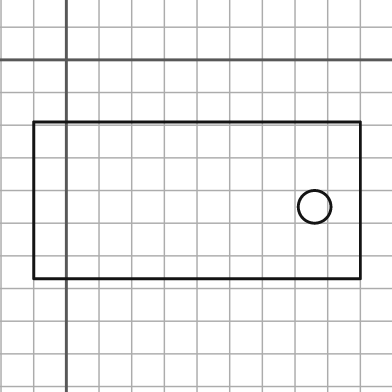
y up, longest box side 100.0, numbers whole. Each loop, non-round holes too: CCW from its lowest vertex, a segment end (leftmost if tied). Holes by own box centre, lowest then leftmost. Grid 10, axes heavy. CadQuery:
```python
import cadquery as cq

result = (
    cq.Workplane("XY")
    .moveTo(-10.0, -67.0)
    .lineTo(90.0, -67.0)
    .lineTo(90.0, -19.0)
    .lineTo(-10.0, -19.0)
    .close()
    .moveTo(76.0, -45.0)
    .circle(5.0)
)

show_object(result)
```